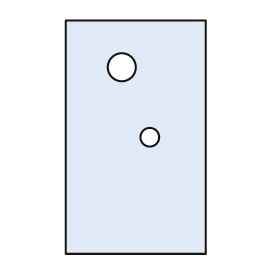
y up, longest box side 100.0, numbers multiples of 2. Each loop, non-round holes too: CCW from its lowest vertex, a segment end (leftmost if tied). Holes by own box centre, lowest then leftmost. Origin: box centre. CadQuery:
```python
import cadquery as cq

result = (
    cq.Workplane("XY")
    .moveTo(-30.0, -50.0)
    .lineTo(30.0, -50.0)
    .lineTo(30.0, 50.0)
    .lineTo(-30.0, 50.0)
    .close()
    .moveTo(6.0, 0.0)
    .circle(4.0)
    .moveTo(-6.0, 30.0)
    .circle(6.0)
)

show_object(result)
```